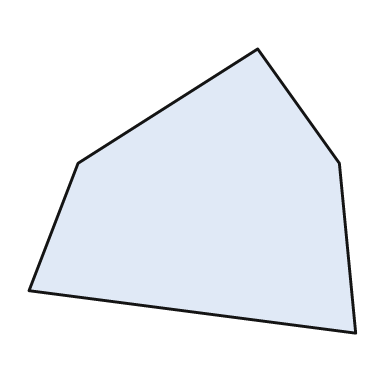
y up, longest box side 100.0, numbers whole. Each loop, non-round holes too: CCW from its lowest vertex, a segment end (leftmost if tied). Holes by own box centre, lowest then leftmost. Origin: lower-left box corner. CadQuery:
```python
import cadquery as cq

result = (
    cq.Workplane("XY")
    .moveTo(100.0, 0.0)
    .lineTo(95.0, 52.0)
    .lineTo(70.0, 87.0)
    .lineTo(15.0, 52.0)
    .lineTo(0.0, 13.0)
    .close()
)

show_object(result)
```